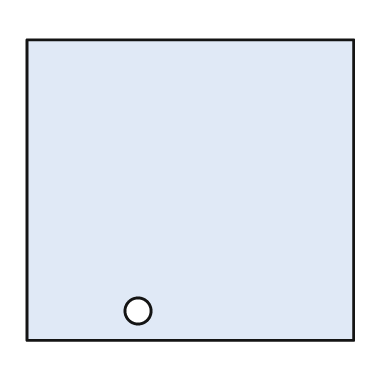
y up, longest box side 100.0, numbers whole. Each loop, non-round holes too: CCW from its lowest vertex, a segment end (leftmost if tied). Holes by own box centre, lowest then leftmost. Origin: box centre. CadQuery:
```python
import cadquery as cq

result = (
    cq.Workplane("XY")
    .moveTo(-50.0, -46.0)
    .lineTo(50.0, -46.0)
    .lineTo(50.0, 46.0)
    .lineTo(-50.0, 46.0)
    .close()
    .moveTo(-16.0, -37.0)
    .circle(4.0)
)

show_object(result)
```